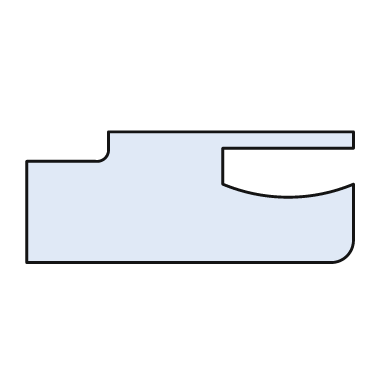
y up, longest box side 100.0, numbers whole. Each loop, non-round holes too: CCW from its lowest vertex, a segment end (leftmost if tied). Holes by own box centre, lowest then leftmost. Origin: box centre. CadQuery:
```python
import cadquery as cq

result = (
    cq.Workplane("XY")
    .moveTo(-50.0, -20.0)
    .lineTo(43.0, -20.0)
    .threePointArc((48.0, -18.0), (50.0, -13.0))
    .lineTo(50.0, 4.0)
    .threePointArc((30.0, 0.0), (10.0, 4.0))
    .lineTo(10.0, 15.0)
    .lineTo(50.0, 15.0)
    .lineTo(50.0, 20.0)
    .lineTo(-25.0, 20.0)
    .lineTo(-25.0, 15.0)
    .threePointArc((-26.0, 12.0), (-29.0, 11.0))
    .lineTo(-50.0, 11.0)
    .close()
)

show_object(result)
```